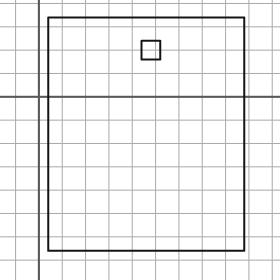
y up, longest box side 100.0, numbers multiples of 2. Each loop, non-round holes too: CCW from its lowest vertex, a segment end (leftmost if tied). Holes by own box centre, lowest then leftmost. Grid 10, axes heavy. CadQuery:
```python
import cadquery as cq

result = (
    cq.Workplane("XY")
    .moveTo(4.0, -66.0)
    .lineTo(88.0, -66.0)
    .lineTo(88.0, 34.0)
    .lineTo(4.0, 34.0)
    .close()
    .moveTo(44.0, 16.0)
    .lineTo(52.0, 16.0)
    .lineTo(52.0, 24.0)
    .lineTo(44.0, 24.0)
    .close()
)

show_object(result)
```